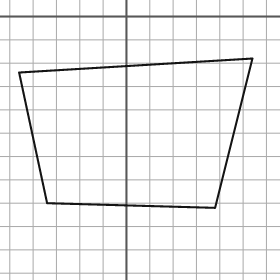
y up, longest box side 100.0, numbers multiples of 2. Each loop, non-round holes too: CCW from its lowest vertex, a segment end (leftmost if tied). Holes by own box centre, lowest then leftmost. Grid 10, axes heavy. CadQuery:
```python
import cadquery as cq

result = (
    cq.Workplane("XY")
    .moveTo(38.0, -82.0)
    .lineTo(54.0, -18.0)
    .lineTo(-46.0, -24.0)
    .lineTo(-34.0, -80.0)
    .close()
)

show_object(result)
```